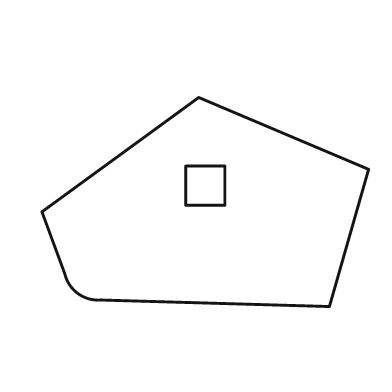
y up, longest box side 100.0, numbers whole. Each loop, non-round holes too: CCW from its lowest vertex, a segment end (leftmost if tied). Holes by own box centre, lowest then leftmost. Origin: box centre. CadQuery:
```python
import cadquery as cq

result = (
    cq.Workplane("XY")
    .moveTo(38.0, -32.0)
    .lineTo(50.0, 10.0)
    .lineTo(-2.0, 32.0)
    .lineTo(-50.0, -3.0)
    .lineTo(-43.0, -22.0)
    .threePointArc((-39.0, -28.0), (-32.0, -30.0))
    .close()
    .moveTo(-6.0, -1.0)
    .lineTo(6.0, -1.0)
    .lineTo(6.0, 11.0)
    .lineTo(-6.0, 11.0)
    .close()
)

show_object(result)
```